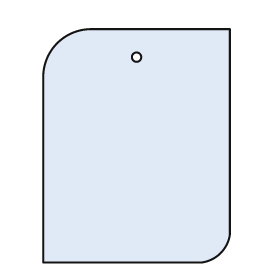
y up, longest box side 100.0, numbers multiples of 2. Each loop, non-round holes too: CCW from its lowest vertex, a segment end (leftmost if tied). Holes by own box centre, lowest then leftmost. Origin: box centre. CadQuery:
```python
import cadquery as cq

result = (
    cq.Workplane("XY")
    .moveTo(-40.0, -50.0)
    .lineTo(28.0, -50.0)
    .threePointArc((36.0, -46.0), (40.0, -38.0))
    .lineTo(40.0, 50.0)
    .lineTo(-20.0, 50.0)
    .threePointArc((-34.0, 44.0), (-40.0, 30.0))
    .close()
    .moveTo(0.0, 38.0)
    .circle(2.0)
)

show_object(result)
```